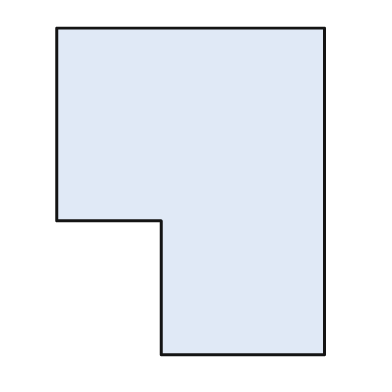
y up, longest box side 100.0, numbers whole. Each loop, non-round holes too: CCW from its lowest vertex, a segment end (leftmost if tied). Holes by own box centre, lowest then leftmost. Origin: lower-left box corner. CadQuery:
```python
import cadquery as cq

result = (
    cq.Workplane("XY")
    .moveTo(32.0, 0.0)
    .lineTo(82.0, 0.0)
    .lineTo(82.0, 100.0)
    .lineTo(0.0, 100.0)
    .lineTo(0.0, 41.0)
    .lineTo(32.0, 41.0)
    .close()
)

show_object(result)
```